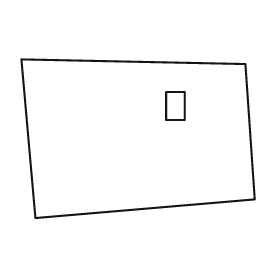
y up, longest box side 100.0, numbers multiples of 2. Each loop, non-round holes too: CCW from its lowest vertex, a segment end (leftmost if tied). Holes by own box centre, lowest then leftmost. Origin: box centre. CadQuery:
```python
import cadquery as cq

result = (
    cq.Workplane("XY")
    .moveTo(-44.0, -34.0)
    .lineTo(50.0, -26.0)
    .lineTo(46.0, 32.0)
    .lineTo(-50.0, 34.0)
    .close()
    .moveTo(12.0, 8.0)
    .lineTo(20.0, 8.0)
    .lineTo(20.0, 20.0)
    .lineTo(12.0, 20.0)
    .close()
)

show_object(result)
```